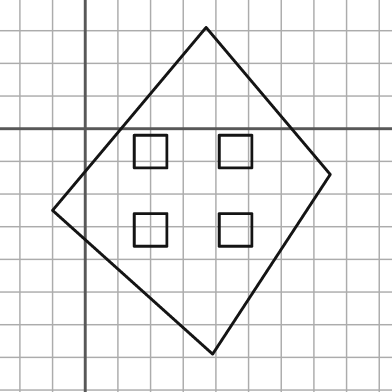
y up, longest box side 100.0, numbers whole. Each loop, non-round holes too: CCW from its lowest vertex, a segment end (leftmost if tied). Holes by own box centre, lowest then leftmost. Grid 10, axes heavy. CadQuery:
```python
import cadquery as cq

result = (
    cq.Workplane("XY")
    .moveTo(39.0, -69.0)
    .lineTo(75.0, -14.0)
    .lineTo(37.0, 31.0)
    .lineTo(-10.0, -25.0)
    .close()
    .moveTo(15.0, -36.0)
    .lineTo(25.0, -36.0)
    .lineTo(25.0, -26.0)
    .lineTo(15.0, -26.0)
    .close()
    .moveTo(41.0, -36.0)
    .lineTo(51.0, -36.0)
    .lineTo(51.0, -26.0)
    .lineTo(41.0, -26.0)
    .close()
    .moveTo(15.0, -12.0)
    .lineTo(25.0, -12.0)
    .lineTo(25.0, -2.0)
    .lineTo(15.0, -2.0)
    .close()
    .moveTo(41.0, -12.0)
    .lineTo(51.0, -12.0)
    .lineTo(51.0, -2.0)
    .lineTo(41.0, -2.0)
    .close()
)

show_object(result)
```